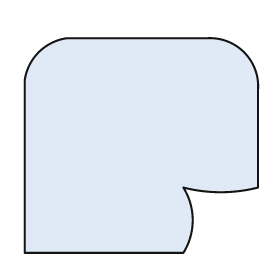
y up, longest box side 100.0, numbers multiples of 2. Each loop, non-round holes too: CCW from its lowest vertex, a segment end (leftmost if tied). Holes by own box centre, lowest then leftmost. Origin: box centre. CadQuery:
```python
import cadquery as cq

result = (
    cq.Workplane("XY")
    .moveTo(-50.0, -46.0)
    .lineTo(18.0, -46.0)
    .threePointArc((22.0, -32.0), (18.0, -18.0))
    .threePointArc((34.0, -20.0), (50.0, -18.0))
    .lineTo(50.0, 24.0)
    .threePointArc((44.0, 40.0), (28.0, 46.0))
    .lineTo(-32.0, 46.0)
    .threePointArc((-44.0, 40.0), (-50.0, 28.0))
    .close()
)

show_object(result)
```